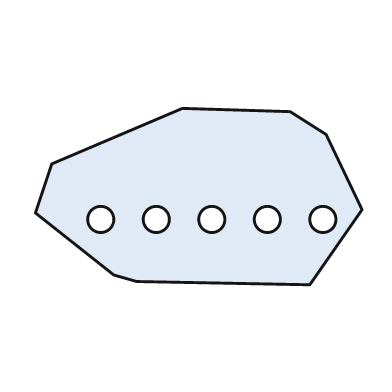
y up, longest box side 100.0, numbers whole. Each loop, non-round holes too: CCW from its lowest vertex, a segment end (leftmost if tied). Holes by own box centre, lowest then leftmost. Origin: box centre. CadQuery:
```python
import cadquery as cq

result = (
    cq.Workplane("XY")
    .moveTo(34.0, -27.0)
    .lineTo(50.0, -4.0)
    .lineTo(39.0, 19.0)
    .lineTo(28.0, 26.0)
    .lineTo(-5.0, 27.0)
    .lineTo(-45.0, 10.0)
    .lineTo(-50.0, -5.0)
    .lineTo(-26.0, -24.0)
    .lineTo(-19.0, -26.0)
    .close()
    .moveTo(-30.0, -7.0)
    .circle(4.0)
    .moveTo(-13.0, -7.0)
    .circle(4.0)
    .moveTo(4.0, -7.0)
    .circle(4.0)
    .moveTo(21.0, -7.0)
    .circle(4.0)
    .moveTo(38.0, -7.0)
    .circle(4.0)
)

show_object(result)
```